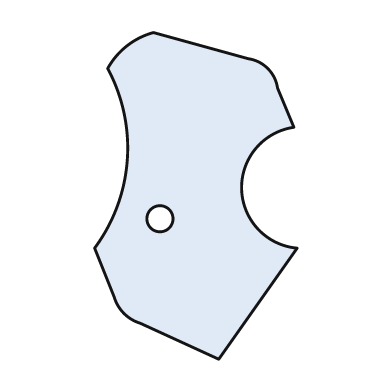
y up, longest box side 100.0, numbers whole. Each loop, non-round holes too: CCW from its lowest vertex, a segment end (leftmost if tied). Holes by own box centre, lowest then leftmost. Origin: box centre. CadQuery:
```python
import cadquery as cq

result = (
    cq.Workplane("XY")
    .moveTo(7.0, -50.0)
    .lineTo(31.0, -16.0)
    .threePointArc((14.0, 2.0), (30.0, 21.0))
    .lineTo(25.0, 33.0)
    .threePointArc((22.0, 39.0), (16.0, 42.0))
    .lineTo(-13.0, 50.0)
    .threePointArc((-21.0, 46.0), (-27.0, 39.0))
    .threePointArc((-21.0, 11.0), (-31.0, -16.0))
    .lineTo(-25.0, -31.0)
    .threePointArc((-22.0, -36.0), (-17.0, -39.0))
    .close()
    .moveTo(-11.0, -7.0)
    .circle(4.0)
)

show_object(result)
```